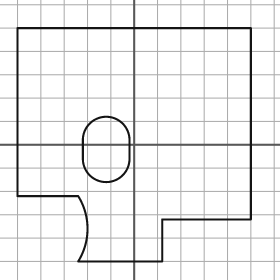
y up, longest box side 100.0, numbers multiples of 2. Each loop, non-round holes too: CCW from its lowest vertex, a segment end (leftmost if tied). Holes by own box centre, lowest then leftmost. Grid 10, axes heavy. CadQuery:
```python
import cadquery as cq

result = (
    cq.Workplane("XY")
    .moveTo(-24.0, -50.0)
    .lineTo(12.0, -50.0)
    .lineTo(12.0, -32.0)
    .lineTo(50.0, -32.0)
    .lineTo(50.0, 50.0)
    .lineTo(-50.0, 50.0)
    .lineTo(-50.0, -22.0)
    .lineTo(-24.0, -22.0)
    .threePointArc((-20.0, -36.0), (-24.0, -50.0))
    .close()
    .moveTo(-22.0, -6.0)
    .threePointArc((-12.0, -16.0), (-2.0, -6.0))
    .lineTo(-2.0, 2.0)
    .threePointArc((-12.0, 12.0), (-22.0, 2.0))
    .close()
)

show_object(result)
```